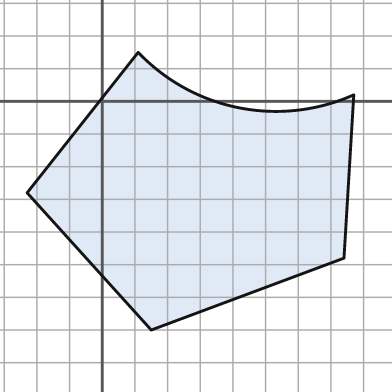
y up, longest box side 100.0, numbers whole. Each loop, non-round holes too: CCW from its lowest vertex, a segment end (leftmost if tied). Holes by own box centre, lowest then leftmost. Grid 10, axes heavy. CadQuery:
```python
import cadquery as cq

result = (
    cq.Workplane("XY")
    .moveTo(15.0, -70.0)
    .lineTo(74.0, -48.0)
    .lineTo(77.0, 2.0)
    .threePointArc((42.0, -2.0), (11.0, 15.0))
    .lineTo(-23.0, -28.0)
    .close()
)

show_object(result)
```